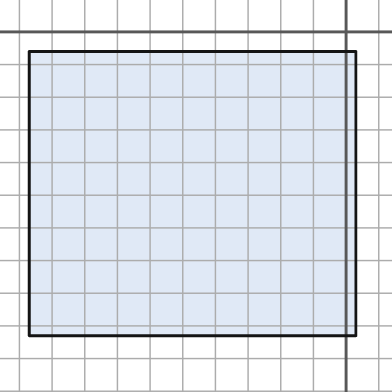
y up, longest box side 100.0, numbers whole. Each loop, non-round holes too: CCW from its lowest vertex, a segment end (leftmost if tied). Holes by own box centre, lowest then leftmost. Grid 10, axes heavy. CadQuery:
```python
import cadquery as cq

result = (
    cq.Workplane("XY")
    .moveTo(-97.0, -93.0)
    .lineTo(3.0, -93.0)
    .lineTo(3.0, -6.0)
    .lineTo(-97.0, -6.0)
    .close()
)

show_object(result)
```